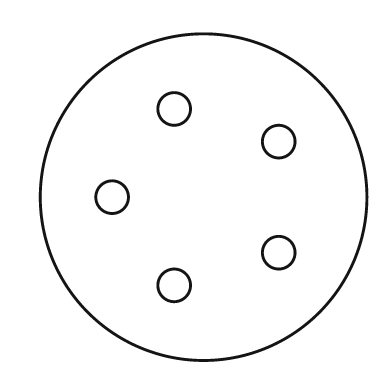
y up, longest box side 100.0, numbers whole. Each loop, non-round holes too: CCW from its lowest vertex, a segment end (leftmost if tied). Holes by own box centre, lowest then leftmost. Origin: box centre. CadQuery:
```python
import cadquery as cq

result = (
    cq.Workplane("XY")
    .moveTo(0.0, 0.0)
    .circle(50.0)
    .moveTo(-9.0, -27.0)
    .circle(5.0)
    .moveTo(23.0, -17.0)
    .circle(5.0)
    .moveTo(-28.0, 0.0)
    .circle(5.0)
    .moveTo(23.0, 17.0)
    .circle(5.0)
    .moveTo(-9.0, 27.0)
    .circle(5.0)
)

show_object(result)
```